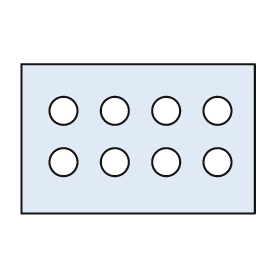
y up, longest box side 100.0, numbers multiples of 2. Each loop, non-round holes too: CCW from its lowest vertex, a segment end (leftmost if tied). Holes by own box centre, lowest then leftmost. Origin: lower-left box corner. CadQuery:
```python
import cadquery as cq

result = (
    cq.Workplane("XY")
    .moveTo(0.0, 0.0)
    .lineTo(100.0, 0.0)
    .lineTo(100.0, 64.0)
    .lineTo(0.0, 64.0)
    .close()
    .moveTo(18.0, 22.0)
    .circle(6.0)
    .moveTo(40.0, 22.0)
    .circle(6.0)
    .moveTo(62.0, 22.0)
    .circle(6.0)
    .moveTo(84.0, 22.0)
    .circle(6.0)
    .moveTo(18.0, 44.0)
    .circle(6.0)
    .moveTo(40.0, 44.0)
    .circle(6.0)
    .moveTo(62.0, 44.0)
    .circle(6.0)
    .moveTo(84.0, 44.0)
    .circle(6.0)
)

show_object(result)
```